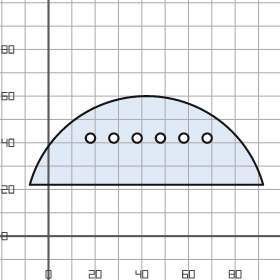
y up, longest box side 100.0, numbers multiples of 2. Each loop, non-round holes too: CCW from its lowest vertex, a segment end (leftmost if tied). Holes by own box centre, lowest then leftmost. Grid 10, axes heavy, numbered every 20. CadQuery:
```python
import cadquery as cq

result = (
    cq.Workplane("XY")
    .moveTo(-8.0, 22.0)
    .lineTo(92.0, 22.0)
    .threePointArc((42.0, 60.0), (-8.0, 22.0))
    .close()
    .moveTo(18.0, 42.0)
    .circle(2.0)
    .moveTo(28.0, 42.0)
    .circle(2.0)
    .moveTo(38.0, 42.0)
    .circle(2.0)
    .moveTo(48.0, 42.0)
    .circle(2.0)
    .moveTo(58.0, 42.0)
    .circle(2.0)
    .moveTo(68.0, 42.0)
    .circle(2.0)
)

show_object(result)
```